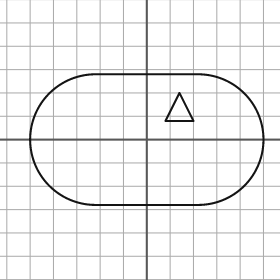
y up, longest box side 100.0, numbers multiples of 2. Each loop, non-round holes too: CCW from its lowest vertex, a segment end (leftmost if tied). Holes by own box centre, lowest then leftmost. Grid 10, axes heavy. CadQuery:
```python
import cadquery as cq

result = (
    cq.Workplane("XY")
    .moveTo(-22.0, -28.0)
    .lineTo(22.0, -28.0)
    .threePointArc((50.0, 0.0), (22.0, 28.0))
    .lineTo(-22.0, 28.0)
    .threePointArc((-50.0, 0.0), (-22.0, -28.0))
    .close()
    .moveTo(8.0, 8.0)
    .lineTo(20.0, 8.0)
    .lineTo(14.0, 20.0)
    .close()
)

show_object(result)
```